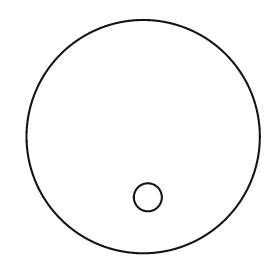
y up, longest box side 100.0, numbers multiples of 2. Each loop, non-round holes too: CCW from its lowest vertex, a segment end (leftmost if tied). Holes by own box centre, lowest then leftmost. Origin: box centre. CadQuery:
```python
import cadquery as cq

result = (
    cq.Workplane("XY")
    .moveTo(0.0, 0.0)
    .circle(50.0)
    .moveTo(2.0, -26.0)
    .circle(6.0)
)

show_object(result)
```